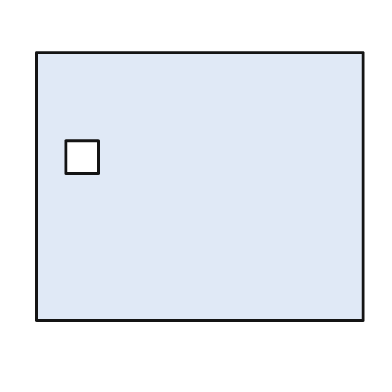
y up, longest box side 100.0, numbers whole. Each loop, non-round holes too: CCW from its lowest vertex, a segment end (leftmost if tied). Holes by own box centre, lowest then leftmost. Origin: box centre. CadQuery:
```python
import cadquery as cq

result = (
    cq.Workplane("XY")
    .moveTo(-50.0, -41.0)
    .lineTo(50.0, -41.0)
    .lineTo(50.0, 41.0)
    .lineTo(-50.0, 41.0)
    .close()
    .moveTo(-41.0, 4.0)
    .lineTo(-31.0, 4.0)
    .lineTo(-31.0, 14.0)
    .lineTo(-41.0, 14.0)
    .close()
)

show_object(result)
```